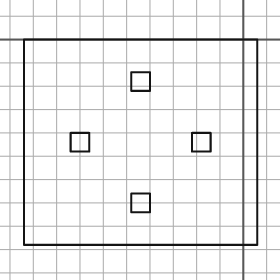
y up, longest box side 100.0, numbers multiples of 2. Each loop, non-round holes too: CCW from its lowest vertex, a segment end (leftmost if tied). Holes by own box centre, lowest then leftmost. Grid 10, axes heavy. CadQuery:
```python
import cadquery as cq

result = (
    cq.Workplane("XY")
    .moveTo(-94.0, -88.0)
    .lineTo(6.0, -88.0)
    .lineTo(6.0, 0.0)
    .lineTo(-94.0, 0.0)
    .close()
    .moveTo(-48.0, -74.0)
    .lineTo(-40.0, -74.0)
    .lineTo(-40.0, -66.0)
    .lineTo(-48.0, -66.0)
    .close()
    .moveTo(-74.0, -48.0)
    .lineTo(-66.0, -48.0)
    .lineTo(-66.0, -40.0)
    .lineTo(-74.0, -40.0)
    .close()
    .moveTo(-22.0, -48.0)
    .lineTo(-14.0, -48.0)
    .lineTo(-14.0, -40.0)
    .lineTo(-22.0, -40.0)
    .close()
    .moveTo(-48.0, -22.0)
    .lineTo(-40.0, -22.0)
    .lineTo(-40.0, -14.0)
    .lineTo(-48.0, -14.0)
    .close()
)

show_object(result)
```